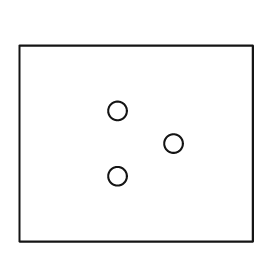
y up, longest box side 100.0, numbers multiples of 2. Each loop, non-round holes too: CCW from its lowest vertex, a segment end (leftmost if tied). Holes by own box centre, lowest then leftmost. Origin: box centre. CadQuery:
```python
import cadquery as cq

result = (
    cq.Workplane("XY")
    .moveTo(-50.0, -42.0)
    .lineTo(50.0, -42.0)
    .lineTo(50.0, 42.0)
    .lineTo(-50.0, 42.0)
    .close()
    .moveTo(-8.0, -14.0)
    .circle(4.0)
    .moveTo(16.0, 0.0)
    .circle(4.0)
    .moveTo(-8.0, 14.0)
    .circle(4.0)
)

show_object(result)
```